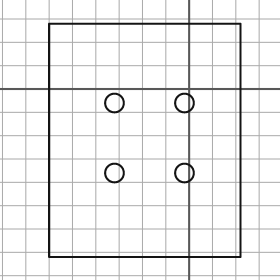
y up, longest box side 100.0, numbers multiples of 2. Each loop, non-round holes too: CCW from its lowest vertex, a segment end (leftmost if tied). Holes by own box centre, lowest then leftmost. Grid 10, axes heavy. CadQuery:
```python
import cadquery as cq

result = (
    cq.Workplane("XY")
    .moveTo(-60.0, -72.0)
    .lineTo(22.0, -72.0)
    .lineTo(22.0, 28.0)
    .lineTo(-60.0, 28.0)
    .close()
    .moveTo(-32.0, -36.0)
    .circle(4.0)
    .moveTo(-2.0, -36.0)
    .circle(4.0)
    .moveTo(-32.0, -6.0)
    .circle(4.0)
    .moveTo(-2.0, -6.0)
    .circle(4.0)
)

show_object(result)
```